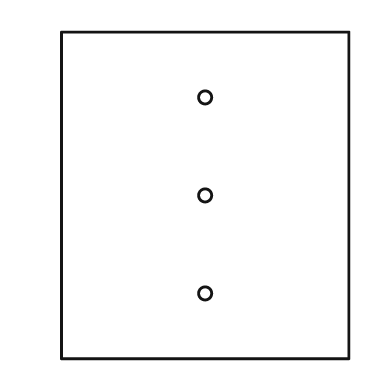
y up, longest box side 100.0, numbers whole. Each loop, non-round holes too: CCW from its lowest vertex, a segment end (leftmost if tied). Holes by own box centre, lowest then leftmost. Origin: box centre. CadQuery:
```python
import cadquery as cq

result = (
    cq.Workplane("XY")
    .moveTo(-44.0, -50.0)
    .lineTo(44.0, -50.0)
    .lineTo(44.0, 50.0)
    .lineTo(-44.0, 50.0)
    .close()
    .moveTo(0.0, -30.0)
    .circle(2.0)
    .moveTo(0.0, 0.0)
    .circle(2.0)
    .moveTo(0.0, 30.0)
    .circle(2.0)
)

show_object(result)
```